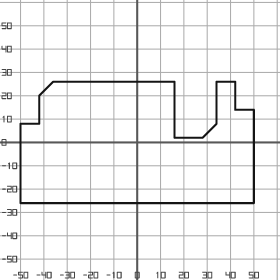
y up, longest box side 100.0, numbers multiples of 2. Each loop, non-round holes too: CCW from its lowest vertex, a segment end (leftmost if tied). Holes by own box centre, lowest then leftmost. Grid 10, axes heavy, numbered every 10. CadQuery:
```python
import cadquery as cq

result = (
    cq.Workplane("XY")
    .moveTo(-50.0, -26.0)
    .lineTo(50.0, -26.0)
    .lineTo(50.0, 14.0)
    .lineTo(42.0, 14.0)
    .lineTo(42.0, 26.0)
    .lineTo(34.0, 26.0)
    .lineTo(34.0, 8.0)
    .lineTo(28.0, 2.0)
    .lineTo(16.0, 2.0)
    .lineTo(16.0, 26.0)
    .lineTo(-36.0, 26.0)
    .lineTo(-42.0, 20.0)
    .lineTo(-42.0, 8.0)
    .lineTo(-50.0, 8.0)
    .close()
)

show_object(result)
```